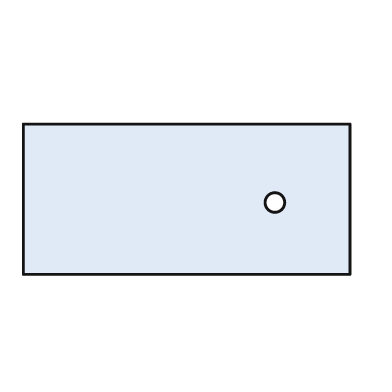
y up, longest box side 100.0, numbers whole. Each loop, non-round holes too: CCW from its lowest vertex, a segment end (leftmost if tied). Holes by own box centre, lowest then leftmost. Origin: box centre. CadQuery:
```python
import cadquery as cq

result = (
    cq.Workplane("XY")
    .moveTo(-50.0, -23.0)
    .lineTo(50.0, -23.0)
    .lineTo(50.0, 23.0)
    .lineTo(-50.0, 23.0)
    .close()
    .moveTo(27.0, -1.0)
    .circle(3.0)
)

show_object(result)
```